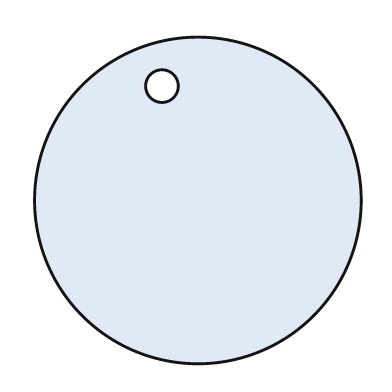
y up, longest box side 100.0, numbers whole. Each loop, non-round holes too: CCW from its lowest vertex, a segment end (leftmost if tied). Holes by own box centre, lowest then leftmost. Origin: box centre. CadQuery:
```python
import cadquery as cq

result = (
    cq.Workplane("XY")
    .moveTo(0.0, 0.0)
    .circle(50.0)
    .moveTo(-11.0, 35.0)
    .circle(5.0)
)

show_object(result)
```